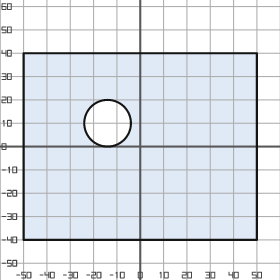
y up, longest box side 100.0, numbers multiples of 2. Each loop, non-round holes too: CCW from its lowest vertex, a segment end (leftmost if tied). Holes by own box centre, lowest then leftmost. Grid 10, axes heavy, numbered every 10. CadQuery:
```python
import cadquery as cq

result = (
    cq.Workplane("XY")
    .moveTo(-50.0, -40.0)
    .lineTo(50.0, -40.0)
    .lineTo(50.0, 40.0)
    .lineTo(-50.0, 40.0)
    .close()
    .moveTo(-14.0, 10.0)
    .circle(10.0)
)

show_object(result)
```